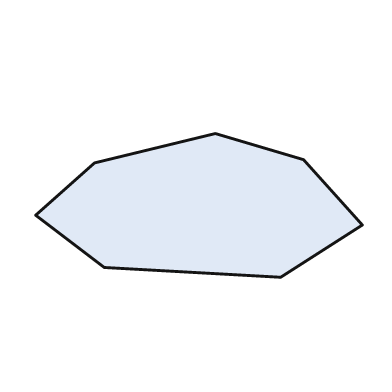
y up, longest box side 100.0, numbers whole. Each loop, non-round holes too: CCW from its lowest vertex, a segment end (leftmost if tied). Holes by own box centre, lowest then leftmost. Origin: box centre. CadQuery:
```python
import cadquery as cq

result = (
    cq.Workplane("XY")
    .moveTo(25.0, -22.0)
    .lineTo(50.0, -6.0)
    .lineTo(32.0, 14.0)
    .lineTo(5.0, 22.0)
    .lineTo(-32.0, 13.0)
    .lineTo(-50.0, -3.0)
    .lineTo(-29.0, -19.0)
    .close()
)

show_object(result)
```